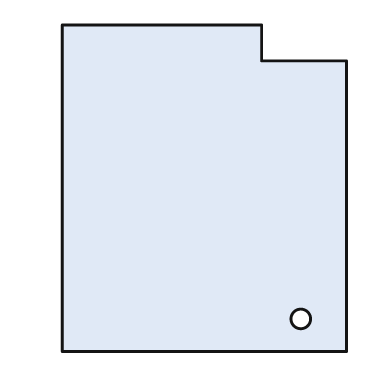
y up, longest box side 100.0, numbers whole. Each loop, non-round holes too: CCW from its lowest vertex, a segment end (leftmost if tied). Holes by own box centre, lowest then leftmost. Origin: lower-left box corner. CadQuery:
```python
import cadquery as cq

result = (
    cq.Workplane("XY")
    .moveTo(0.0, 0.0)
    .lineTo(87.0, 0.0)
    .lineTo(87.0, 89.0)
    .lineTo(61.0, 89.0)
    .lineTo(61.0, 100.0)
    .lineTo(0.0, 100.0)
    .close()
    .moveTo(73.0, 10.0)
    .circle(3.0)
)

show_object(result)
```